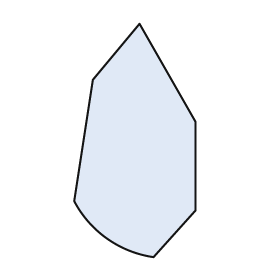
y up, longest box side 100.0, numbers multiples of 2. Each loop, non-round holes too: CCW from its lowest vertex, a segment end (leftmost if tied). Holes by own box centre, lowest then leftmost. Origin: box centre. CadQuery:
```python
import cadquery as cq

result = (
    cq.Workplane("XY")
    .moveTo(8.0, -50.0)
    .lineTo(26.0, -30.0)
    .lineTo(26.0, 8.0)
    .lineTo(2.0, 50.0)
    .lineTo(-18.0, 26.0)
    .lineTo(-26.0, -26.0)
    .threePointArc((-12.0, -42.0), (8.0, -50.0))
    .close()
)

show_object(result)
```